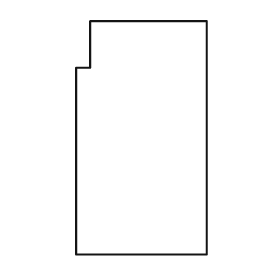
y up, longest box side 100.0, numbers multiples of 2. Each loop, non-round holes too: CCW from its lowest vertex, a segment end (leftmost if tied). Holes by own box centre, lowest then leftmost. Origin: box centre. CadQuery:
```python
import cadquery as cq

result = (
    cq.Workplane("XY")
    .moveTo(-28.0, -50.0)
    .lineTo(28.0, -50.0)
    .lineTo(28.0, 50.0)
    .lineTo(-22.0, 50.0)
    .lineTo(-22.0, 30.0)
    .lineTo(-28.0, 30.0)
    .close()
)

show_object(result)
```